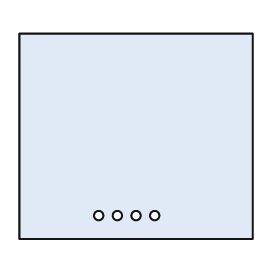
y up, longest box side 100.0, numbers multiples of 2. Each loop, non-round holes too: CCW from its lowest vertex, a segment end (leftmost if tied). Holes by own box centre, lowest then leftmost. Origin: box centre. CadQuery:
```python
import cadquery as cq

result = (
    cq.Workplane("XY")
    .moveTo(-50.0, -44.0)
    .lineTo(50.0, -44.0)
    .lineTo(50.0, 44.0)
    .lineTo(-50.0, 44.0)
    .close()
    .moveTo(-16.0, -34.0)
    .circle(2.0)
    .moveTo(-8.0, -34.0)
    .circle(2.0)
    .moveTo(0.0, -34.0)
    .circle(2.0)
    .moveTo(8.0, -34.0)
    .circle(2.0)
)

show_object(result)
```